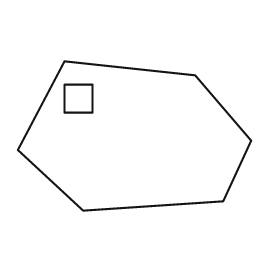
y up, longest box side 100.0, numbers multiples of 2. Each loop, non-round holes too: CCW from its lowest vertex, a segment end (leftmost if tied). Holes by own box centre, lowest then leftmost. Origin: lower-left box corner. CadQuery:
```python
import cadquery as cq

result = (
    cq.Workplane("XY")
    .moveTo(28.0, 0.0)
    .lineTo(88.0, 4.0)
    .lineTo(100.0, 30.0)
    .lineTo(76.0, 58.0)
    .lineTo(20.0, 64.0)
    .lineTo(0.0, 26.0)
    .close()
    .moveTo(20.0, 42.0)
    .lineTo(32.0, 42.0)
    .lineTo(32.0, 54.0)
    .lineTo(20.0, 54.0)
    .close()
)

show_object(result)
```